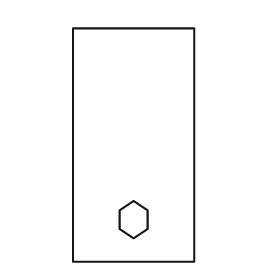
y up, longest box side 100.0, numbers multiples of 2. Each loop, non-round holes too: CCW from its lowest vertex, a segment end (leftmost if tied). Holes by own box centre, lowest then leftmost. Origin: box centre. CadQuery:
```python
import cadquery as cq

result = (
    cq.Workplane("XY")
    .moveTo(-26.0, -50.0)
    .lineTo(26.0, -50.0)
    .lineTo(26.0, 50.0)
    .lineTo(-26.0, 50.0)
    .close()
    .moveTo(0.0, -40.0)
    .lineTo(6.0, -36.0)
    .lineTo(6.0, -28.0)
    .lineTo(0.0, -24.0)
    .lineTo(-6.0, -28.0)
    .lineTo(-6.0, -36.0)
    .close()
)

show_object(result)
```